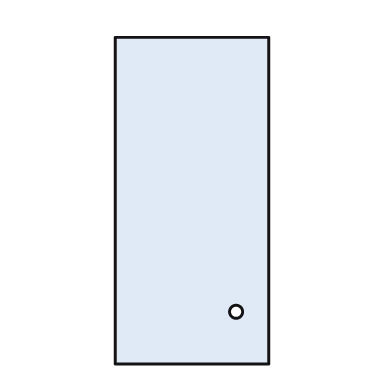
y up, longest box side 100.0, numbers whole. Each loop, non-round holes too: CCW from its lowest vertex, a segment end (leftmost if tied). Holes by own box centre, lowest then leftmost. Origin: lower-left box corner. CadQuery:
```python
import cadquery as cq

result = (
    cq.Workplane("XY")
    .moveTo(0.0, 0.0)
    .lineTo(47.0, 0.0)
    .lineTo(47.0, 100.0)
    .lineTo(0.0, 100.0)
    .close()
    .moveTo(37.0, 16.0)
    .circle(2.0)
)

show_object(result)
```